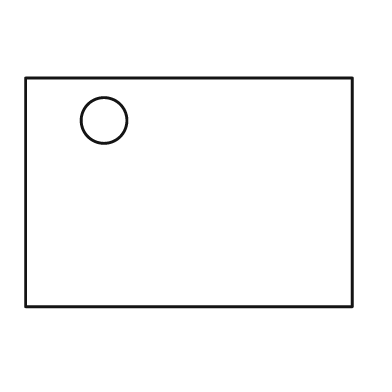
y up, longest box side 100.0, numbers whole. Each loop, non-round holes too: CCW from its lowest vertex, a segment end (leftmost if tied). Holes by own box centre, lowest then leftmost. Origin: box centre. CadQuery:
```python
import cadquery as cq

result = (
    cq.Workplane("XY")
    .moveTo(-50.0, -35.0)
    .lineTo(50.0, -35.0)
    .lineTo(50.0, 35.0)
    .lineTo(-50.0, 35.0)
    .close()
    .moveTo(-26.0, 22.0)
    .circle(7.0)
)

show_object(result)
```